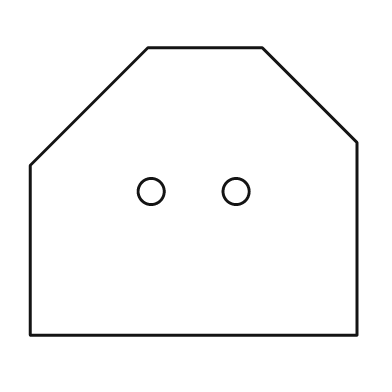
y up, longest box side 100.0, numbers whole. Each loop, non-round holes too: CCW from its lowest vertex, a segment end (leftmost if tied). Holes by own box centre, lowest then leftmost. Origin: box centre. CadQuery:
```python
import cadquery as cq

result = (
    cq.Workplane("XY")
    .moveTo(-50.0, -44.0)
    .lineTo(50.0, -44.0)
    .lineTo(50.0, 15.0)
    .lineTo(21.0, 44.0)
    .lineTo(-14.0, 44.0)
    .lineTo(-50.0, 8.0)
    .close()
    .moveTo(-13.0, 0.0)
    .circle(4.0)
    .moveTo(13.0, 0.0)
    .circle(4.0)
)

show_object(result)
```